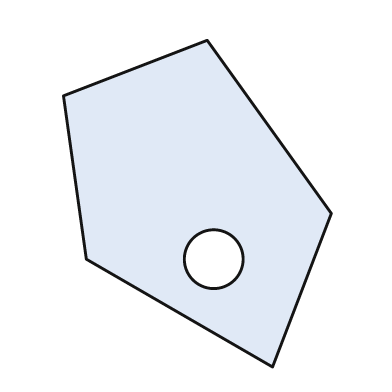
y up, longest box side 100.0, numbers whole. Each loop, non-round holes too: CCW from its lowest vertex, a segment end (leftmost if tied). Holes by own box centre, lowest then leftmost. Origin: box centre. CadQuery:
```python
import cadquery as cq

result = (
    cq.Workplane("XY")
    .moveTo(23.0, -50.0)
    .lineTo(41.0, -3.0)
    .lineTo(3.0, 50.0)
    .lineTo(-41.0, 33.0)
    .lineTo(-34.0, -17.0)
    .close()
    .moveTo(5.0, -17.0)
    .circle(9.0)
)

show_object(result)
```